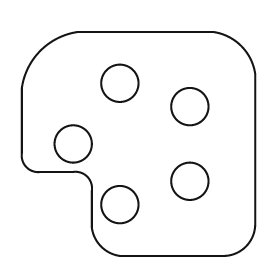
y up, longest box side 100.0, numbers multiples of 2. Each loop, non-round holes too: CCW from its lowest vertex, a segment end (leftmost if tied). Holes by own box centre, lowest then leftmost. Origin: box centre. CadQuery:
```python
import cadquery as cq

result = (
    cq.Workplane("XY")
    .moveTo(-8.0, -48.0)
    .lineTo(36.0, -48.0)
    .threePointArc((46.0, -44.0), (50.0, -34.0))
    .lineTo(50.0, 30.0)
    .threePointArc((44.0, 42.0), (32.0, 48.0))
    .lineTo(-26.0, 48.0)
    .threePointArc((-42.0, 40.0), (-50.0, 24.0))
    .lineTo(-50.0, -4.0)
    .threePointArc((-48.0, -10.0), (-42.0, -12.0))
    .lineTo(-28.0, -12.0)
    .threePointArc((-22.0, -14.0), (-20.0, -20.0))
    .lineTo(-20.0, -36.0)
    .threePointArc((-16.0, -44.0), (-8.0, -48.0))
    .close()
    .moveTo(-8.0, -26.0)
    .circle(8.0)
    .moveTo(22.0, -16.0)
    .circle(8.0)
    .moveTo(-28.0, 0.0)
    .circle(8.0)
    .moveTo(22.0, 16.0)
    .circle(8.0)
    .moveTo(-8.0, 26.0)
    .circle(8.0)
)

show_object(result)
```